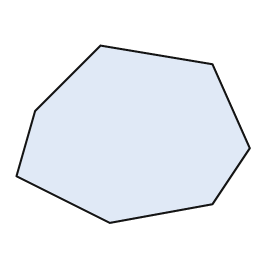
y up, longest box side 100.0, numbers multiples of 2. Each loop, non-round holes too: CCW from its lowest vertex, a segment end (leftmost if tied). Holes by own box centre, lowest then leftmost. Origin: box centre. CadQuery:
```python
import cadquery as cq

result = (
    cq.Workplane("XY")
    .moveTo(-10.0, -38.0)
    .lineTo(34.0, -30.0)
    .lineTo(50.0, -6.0)
    .lineTo(34.0, 30.0)
    .lineTo(-14.0, 38.0)
    .lineTo(-42.0, 10.0)
    .lineTo(-50.0, -18.0)
    .close()
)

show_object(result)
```